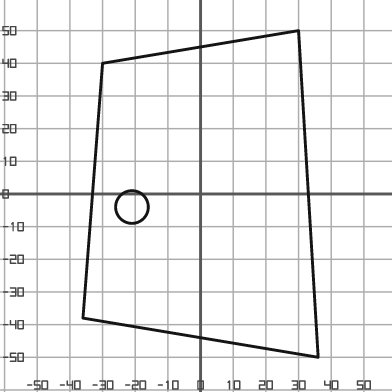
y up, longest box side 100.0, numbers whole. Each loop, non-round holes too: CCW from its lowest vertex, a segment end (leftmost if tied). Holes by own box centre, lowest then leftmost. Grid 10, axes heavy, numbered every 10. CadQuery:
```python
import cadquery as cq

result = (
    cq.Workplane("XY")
    .moveTo(36.0, -50.0)
    .lineTo(30.0, 50.0)
    .lineTo(-30.0, 40.0)
    .lineTo(-36.0, -38.0)
    .close()
    .moveTo(-21.0, -4.0)
    .circle(5.0)
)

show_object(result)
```